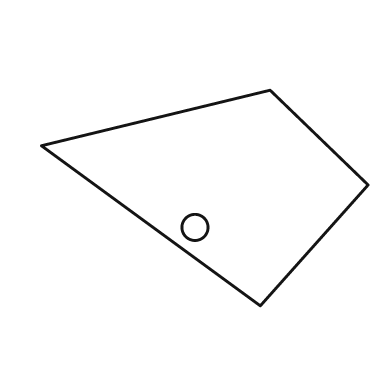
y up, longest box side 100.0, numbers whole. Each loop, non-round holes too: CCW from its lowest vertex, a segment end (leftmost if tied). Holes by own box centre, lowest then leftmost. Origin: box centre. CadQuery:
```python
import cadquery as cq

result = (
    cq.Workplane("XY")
    .moveTo(17.0, -33.0)
    .lineTo(50.0, 4.0)
    .lineTo(20.0, 33.0)
    .lineTo(-50.0, 16.0)
    .close()
    .moveTo(-3.0, -9.0)
    .circle(4.0)
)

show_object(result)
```